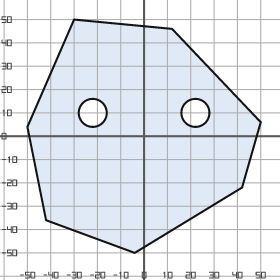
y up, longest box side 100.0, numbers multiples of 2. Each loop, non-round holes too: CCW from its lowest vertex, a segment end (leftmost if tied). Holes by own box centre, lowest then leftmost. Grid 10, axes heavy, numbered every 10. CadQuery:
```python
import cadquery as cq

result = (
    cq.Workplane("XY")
    .moveTo(-4.0, -50.0)
    .lineTo(42.0, -22.0)
    .lineTo(50.0, 6.0)
    .lineTo(12.0, 46.0)
    .lineTo(-30.0, 50.0)
    .lineTo(-50.0, 4.0)
    .lineTo(-42.0, -36.0)
    .close()
    .moveTo(-22.0, 10.0)
    .circle(6.0)
    .moveTo(22.0, 10.0)
    .circle(6.0)
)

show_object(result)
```